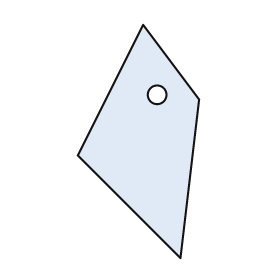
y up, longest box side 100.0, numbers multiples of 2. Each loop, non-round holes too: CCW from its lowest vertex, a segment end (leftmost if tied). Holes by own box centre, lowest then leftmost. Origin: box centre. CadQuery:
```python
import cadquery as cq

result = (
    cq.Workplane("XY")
    .moveTo(18.0, -50.0)
    .lineTo(26.0, 18.0)
    .lineTo(2.0, 50.0)
    .lineTo(-26.0, -6.0)
    .close()
    .moveTo(8.0, 20.0)
    .circle(4.0)
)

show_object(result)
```